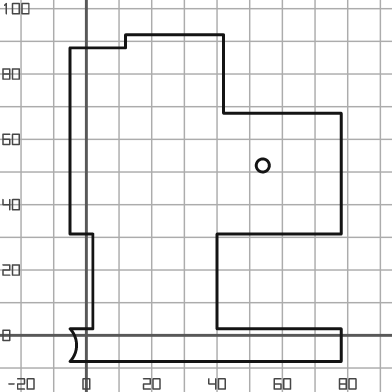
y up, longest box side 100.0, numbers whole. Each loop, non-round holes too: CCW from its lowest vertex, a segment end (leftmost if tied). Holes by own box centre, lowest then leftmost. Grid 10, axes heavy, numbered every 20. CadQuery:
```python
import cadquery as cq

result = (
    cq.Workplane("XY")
    .moveTo(-5.0, -8.0)
    .lineTo(78.0, -8.0)
    .lineTo(78.0, 2.0)
    .lineTo(40.0, 2.0)
    .lineTo(40.0, 31.0)
    .lineTo(78.0, 31.0)
    .lineTo(78.0, 68.0)
    .lineTo(42.0, 68.0)
    .lineTo(42.0, 92.0)
    .lineTo(12.0, 92.0)
    .lineTo(12.0, 88.0)
    .lineTo(-5.0, 88.0)
    .lineTo(-5.0, 31.0)
    .lineTo(2.0, 31.0)
    .lineTo(2.0, 2.0)
    .lineTo(-5.0, 2.0)
    .threePointArc((-3.0, -3.0), (-5.0, -8.0))
    .close()
    .moveTo(54.0, 52.0)
    .circle(2.0)
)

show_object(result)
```